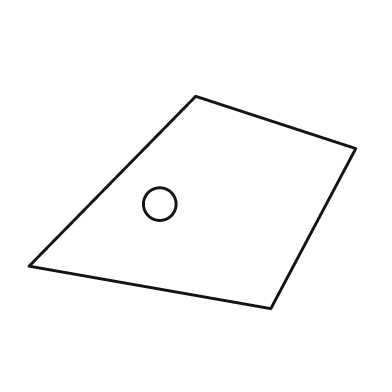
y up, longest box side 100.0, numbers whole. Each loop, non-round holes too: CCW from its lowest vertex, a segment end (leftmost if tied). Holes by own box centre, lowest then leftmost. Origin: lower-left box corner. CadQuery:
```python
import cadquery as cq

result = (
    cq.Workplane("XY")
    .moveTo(74.0, 0.0)
    .lineTo(100.0, 49.0)
    .lineTo(51.0, 65.0)
    .lineTo(0.0, 13.0)
    .close()
    .moveTo(40.0, 32.0)
    .circle(5.0)
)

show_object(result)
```